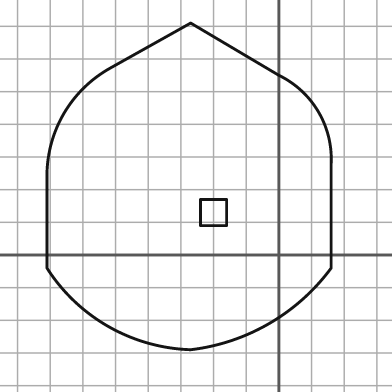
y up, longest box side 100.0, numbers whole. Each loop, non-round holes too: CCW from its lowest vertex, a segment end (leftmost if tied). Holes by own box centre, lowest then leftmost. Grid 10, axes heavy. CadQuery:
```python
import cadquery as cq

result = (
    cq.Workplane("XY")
    .moveTo(-27.0, -29.0)
    .threePointArc((-3.0, -21.0), (16.0, -4.0))
    .lineTo(16.0, 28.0)
    .threePointArc((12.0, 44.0), (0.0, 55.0))
    .lineTo(-27.0, 71.0)
    .lineTo(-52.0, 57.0)
    .threePointArc((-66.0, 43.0), (-71.0, 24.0))
    .lineTo(-71.0, -4.0)
    .threePointArc((-52.0, -22.0), (-27.0, -29.0))
    .close()
    .moveTo(-24.0, 9.0)
    .lineTo(-16.0, 9.0)
    .lineTo(-16.0, 17.0)
    .lineTo(-24.0, 17.0)
    .close()
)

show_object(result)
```